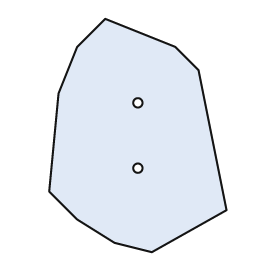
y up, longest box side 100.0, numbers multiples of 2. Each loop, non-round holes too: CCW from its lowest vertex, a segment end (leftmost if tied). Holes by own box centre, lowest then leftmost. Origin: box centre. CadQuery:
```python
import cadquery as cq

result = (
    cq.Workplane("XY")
    .moveTo(6.0, -50.0)
    .lineTo(38.0, -32.0)
    .lineTo(26.0, 28.0)
    .lineTo(16.0, 38.0)
    .lineTo(-14.0, 50.0)
    .lineTo(-26.0, 38.0)
    .lineTo(-34.0, 18.0)
    .lineTo(-38.0, -24.0)
    .lineTo(-26.0, -36.0)
    .lineTo(-10.0, -46.0)
    .close()
    .moveTo(0.0, -14.0)
    .circle(2.0)
    .moveTo(0.0, 14.0)
    .circle(2.0)
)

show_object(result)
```